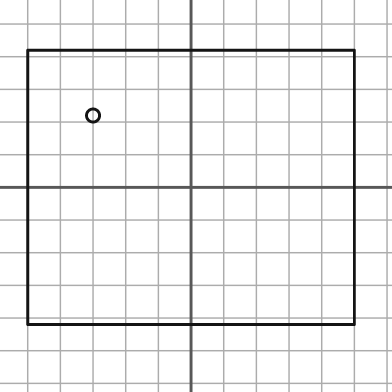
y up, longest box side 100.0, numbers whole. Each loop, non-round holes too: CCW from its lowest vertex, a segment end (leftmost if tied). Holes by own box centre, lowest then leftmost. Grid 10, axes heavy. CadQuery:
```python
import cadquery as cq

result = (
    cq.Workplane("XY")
    .moveTo(-50.0, -42.0)
    .lineTo(50.0, -42.0)
    .lineTo(50.0, 42.0)
    .lineTo(-50.0, 42.0)
    .close()
    .moveTo(-30.0, 22.0)
    .circle(2.0)
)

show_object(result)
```